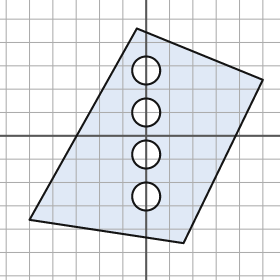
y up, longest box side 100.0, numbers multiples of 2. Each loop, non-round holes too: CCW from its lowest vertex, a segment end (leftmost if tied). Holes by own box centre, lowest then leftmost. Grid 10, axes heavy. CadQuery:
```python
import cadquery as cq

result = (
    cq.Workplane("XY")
    .moveTo(16.0, -46.0)
    .lineTo(50.0, 24.0)
    .lineTo(-4.0, 46.0)
    .lineTo(-50.0, -36.0)
    .close()
    .moveTo(0.0, -26.0)
    .circle(6.0)
    .moveTo(0.0, -8.0)
    .circle(6.0)
    .moveTo(0.0, 10.0)
    .circle(6.0)
    .moveTo(0.0, 28.0)
    .circle(6.0)
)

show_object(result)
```